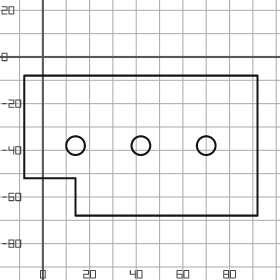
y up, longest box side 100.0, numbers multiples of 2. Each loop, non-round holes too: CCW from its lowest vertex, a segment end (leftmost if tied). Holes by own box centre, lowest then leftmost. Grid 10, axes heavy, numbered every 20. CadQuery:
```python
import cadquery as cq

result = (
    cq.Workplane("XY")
    .moveTo(14.0, -68.0)
    .lineTo(92.0, -68.0)
    .lineTo(92.0, -8.0)
    .lineTo(-8.0, -8.0)
    .lineTo(-8.0, -52.0)
    .lineTo(14.0, -52.0)
    .close()
    .moveTo(14.0, -38.0)
    .circle(4.0)
    .moveTo(42.0, -38.0)
    .circle(4.0)
    .moveTo(70.0, -38.0)
    .circle(4.0)
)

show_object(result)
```